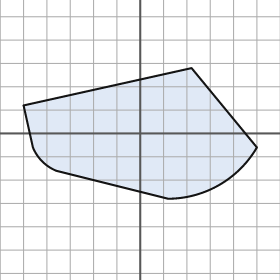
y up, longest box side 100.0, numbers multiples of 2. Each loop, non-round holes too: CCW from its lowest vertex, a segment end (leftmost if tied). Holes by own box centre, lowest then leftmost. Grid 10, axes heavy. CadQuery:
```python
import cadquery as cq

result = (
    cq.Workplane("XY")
    .moveTo(12.0, -28.0)
    .threePointArc((34.0, -22.0), (50.0, -6.0))
    .lineTo(22.0, 28.0)
    .lineTo(-50.0, 12.0)
    .lineTo(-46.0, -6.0)
    .threePointArc((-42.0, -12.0), (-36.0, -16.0))
    .close()
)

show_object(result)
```